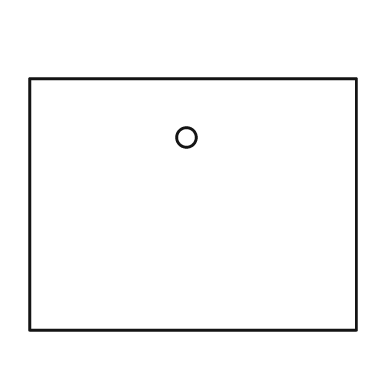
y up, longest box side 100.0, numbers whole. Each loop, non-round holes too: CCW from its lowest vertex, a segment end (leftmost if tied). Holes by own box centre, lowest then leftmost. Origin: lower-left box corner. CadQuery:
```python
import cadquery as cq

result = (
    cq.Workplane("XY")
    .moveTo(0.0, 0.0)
    .lineTo(100.0, 0.0)
    .lineTo(100.0, 77.0)
    .lineTo(0.0, 77.0)
    .close()
    .moveTo(48.0, 59.0)
    .circle(3.0)
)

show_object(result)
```